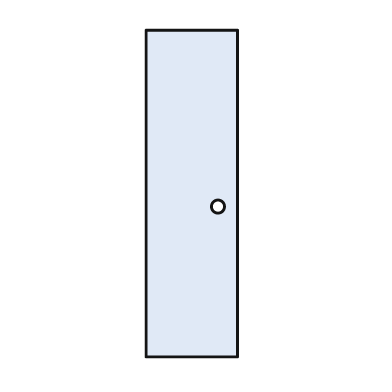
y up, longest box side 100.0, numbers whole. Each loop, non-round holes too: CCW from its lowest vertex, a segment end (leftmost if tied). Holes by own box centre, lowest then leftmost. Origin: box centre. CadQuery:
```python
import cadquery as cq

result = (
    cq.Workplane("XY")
    .moveTo(-14.0, -50.0)
    .lineTo(14.0, -50.0)
    .lineTo(14.0, 50.0)
    .lineTo(-14.0, 50.0)
    .close()
    .moveTo(8.0, -4.0)
    .circle(2.0)
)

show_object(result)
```